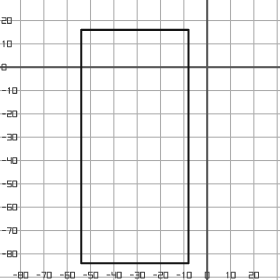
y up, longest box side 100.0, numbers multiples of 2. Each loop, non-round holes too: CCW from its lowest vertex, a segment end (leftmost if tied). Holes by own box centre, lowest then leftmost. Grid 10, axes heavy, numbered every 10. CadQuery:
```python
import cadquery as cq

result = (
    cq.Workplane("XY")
    .moveTo(-54.0, -84.0)
    .lineTo(-8.0, -84.0)
    .lineTo(-8.0, 16.0)
    .lineTo(-54.0, 16.0)
    .close()
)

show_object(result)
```